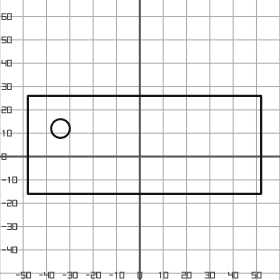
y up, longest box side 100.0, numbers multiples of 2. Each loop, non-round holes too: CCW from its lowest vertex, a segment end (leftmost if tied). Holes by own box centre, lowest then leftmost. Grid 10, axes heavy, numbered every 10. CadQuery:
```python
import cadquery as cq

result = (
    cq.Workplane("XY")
    .moveTo(-48.0, -16.0)
    .lineTo(52.0, -16.0)
    .lineTo(52.0, 26.0)
    .lineTo(-48.0, 26.0)
    .close()
    .moveTo(-34.0, 12.0)
    .circle(4.0)
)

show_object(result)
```